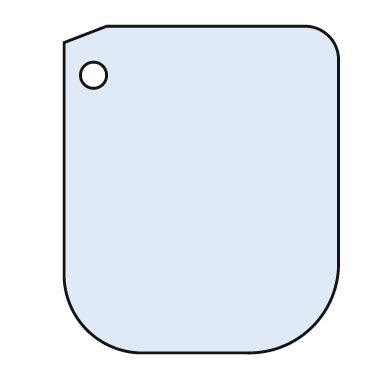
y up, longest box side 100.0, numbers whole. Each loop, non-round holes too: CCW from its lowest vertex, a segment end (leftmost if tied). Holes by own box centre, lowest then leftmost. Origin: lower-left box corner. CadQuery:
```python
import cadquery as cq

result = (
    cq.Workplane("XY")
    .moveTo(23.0, 0.0)
    .lineTo(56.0, 0.0)
    .threePointArc((76.0, 8.0), (84.0, 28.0))
    .lineTo(84.0, 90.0)
    .threePointArc((81.0, 97.0), (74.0, 100.0))
    .lineTo(13.0, 100.0)
    .lineTo(0.0, 95.0)
    .lineTo(0.0, 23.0)
    .threePointArc((7.0, 7.0), (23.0, 0.0))
    .close()
    .moveTo(9.0, 85.0)
    .circle(4.0)
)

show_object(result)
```